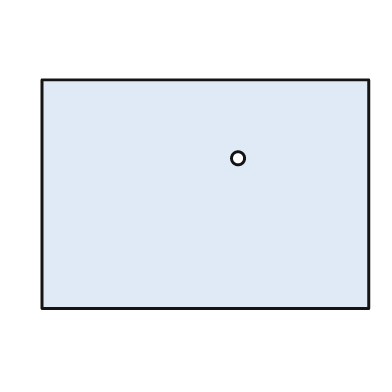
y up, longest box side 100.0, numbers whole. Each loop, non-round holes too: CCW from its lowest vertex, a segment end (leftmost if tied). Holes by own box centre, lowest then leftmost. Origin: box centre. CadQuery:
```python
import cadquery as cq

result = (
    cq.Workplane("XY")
    .moveTo(-50.0, -35.0)
    .lineTo(50.0, -35.0)
    .lineTo(50.0, 35.0)
    .lineTo(-50.0, 35.0)
    .close()
    .moveTo(10.0, 11.0)
    .circle(2.0)
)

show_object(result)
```